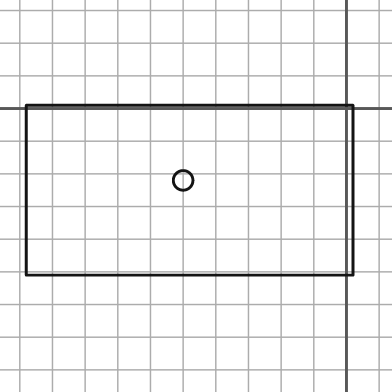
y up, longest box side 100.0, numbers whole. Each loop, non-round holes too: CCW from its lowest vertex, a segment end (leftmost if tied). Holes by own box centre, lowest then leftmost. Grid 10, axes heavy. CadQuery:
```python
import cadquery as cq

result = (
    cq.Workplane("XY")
    .moveTo(-98.0, -51.0)
    .lineTo(2.0, -51.0)
    .lineTo(2.0, 1.0)
    .lineTo(-98.0, 1.0)
    .close()
    .moveTo(-50.0, -22.0)
    .circle(3.0)
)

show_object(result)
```